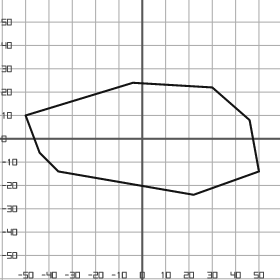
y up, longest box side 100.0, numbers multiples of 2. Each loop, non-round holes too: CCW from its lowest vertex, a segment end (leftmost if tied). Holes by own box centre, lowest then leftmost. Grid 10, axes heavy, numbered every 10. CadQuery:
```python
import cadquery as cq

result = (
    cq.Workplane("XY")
    .moveTo(22.0, -24.0)
    .lineTo(50.0, -14.0)
    .lineTo(46.0, 8.0)
    .lineTo(30.0, 22.0)
    .lineTo(-4.0, 24.0)
    .lineTo(-50.0, 10.0)
    .lineTo(-44.0, -6.0)
    .lineTo(-36.0, -14.0)
    .close()
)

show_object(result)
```